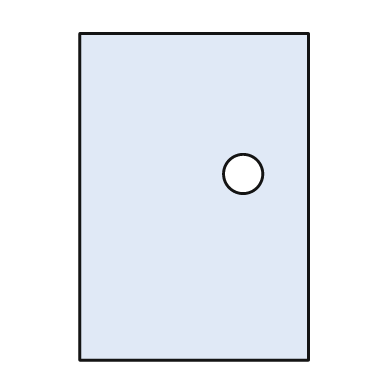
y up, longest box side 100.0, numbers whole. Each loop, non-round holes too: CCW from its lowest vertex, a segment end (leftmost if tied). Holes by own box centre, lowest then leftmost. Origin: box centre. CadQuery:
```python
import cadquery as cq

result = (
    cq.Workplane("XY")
    .moveTo(-35.0, -50.0)
    .lineTo(35.0, -50.0)
    .lineTo(35.0, 50.0)
    .lineTo(-35.0, 50.0)
    .close()
    .moveTo(15.0, 7.0)
    .circle(6.0)
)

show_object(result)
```